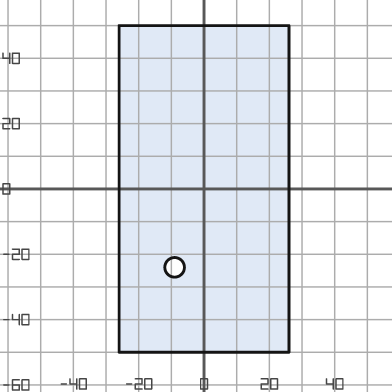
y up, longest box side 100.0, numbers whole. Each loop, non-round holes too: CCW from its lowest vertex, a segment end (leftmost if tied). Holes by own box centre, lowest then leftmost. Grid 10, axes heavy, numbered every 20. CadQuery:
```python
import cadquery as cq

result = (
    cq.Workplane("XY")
    .moveTo(-26.0, -50.0)
    .lineTo(26.0, -50.0)
    .lineTo(26.0, 50.0)
    .lineTo(-26.0, 50.0)
    .close()
    .moveTo(-9.0, -24.0)
    .circle(3.0)
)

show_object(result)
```